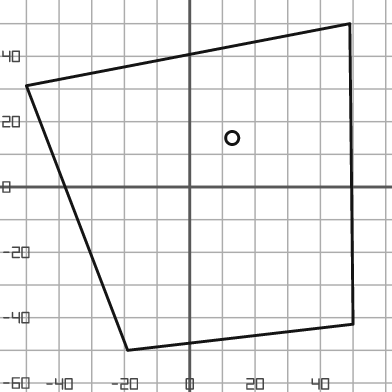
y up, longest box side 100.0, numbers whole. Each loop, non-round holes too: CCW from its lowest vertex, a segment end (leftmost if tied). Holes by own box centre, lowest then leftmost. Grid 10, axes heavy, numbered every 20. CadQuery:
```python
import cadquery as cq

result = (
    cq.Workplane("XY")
    .moveTo(-19.0, -50.0)
    .lineTo(50.0, -42.0)
    .lineTo(49.0, 50.0)
    .lineTo(-50.0, 31.0)
    .close()
    .moveTo(13.0, 15.0)
    .circle(2.0)
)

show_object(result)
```